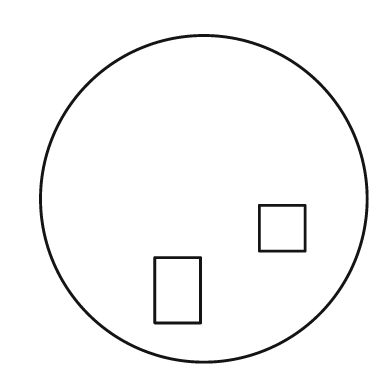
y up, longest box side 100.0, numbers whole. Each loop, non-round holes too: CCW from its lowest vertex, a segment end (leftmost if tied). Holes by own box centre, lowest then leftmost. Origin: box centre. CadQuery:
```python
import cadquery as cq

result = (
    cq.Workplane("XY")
    .moveTo(0.0, 0.0)
    .circle(50.0)
    .moveTo(-15.0, -38.0)
    .lineTo(-1.0, -38.0)
    .lineTo(-1.0, -18.0)
    .lineTo(-15.0, -18.0)
    .close()
    .moveTo(17.0, -16.0)
    .lineTo(31.0, -16.0)
    .lineTo(31.0, -2.0)
    .lineTo(17.0, -2.0)
    .close()
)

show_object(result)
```